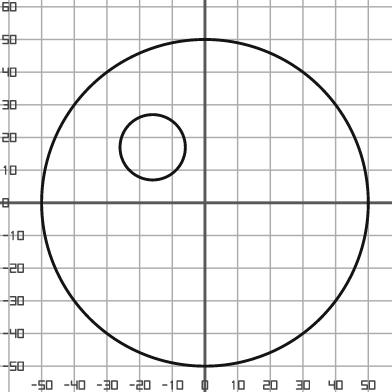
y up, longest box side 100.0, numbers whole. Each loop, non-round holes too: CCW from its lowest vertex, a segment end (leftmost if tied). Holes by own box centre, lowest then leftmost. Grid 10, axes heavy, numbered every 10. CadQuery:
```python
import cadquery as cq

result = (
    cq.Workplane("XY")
    .moveTo(0.0, 0.0)
    .circle(50.0)
    .moveTo(-16.0, 17.0)
    .circle(10.0)
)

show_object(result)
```